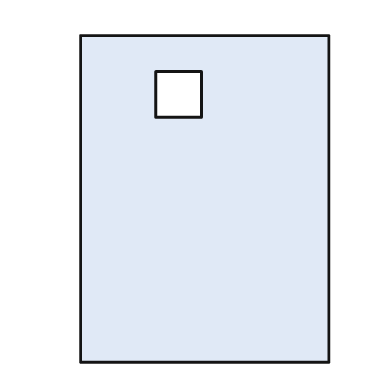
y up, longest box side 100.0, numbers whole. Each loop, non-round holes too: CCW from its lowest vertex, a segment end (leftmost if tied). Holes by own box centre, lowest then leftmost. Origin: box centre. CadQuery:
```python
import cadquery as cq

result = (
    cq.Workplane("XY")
    .moveTo(-38.0, -50.0)
    .lineTo(38.0, -50.0)
    .lineTo(38.0, 50.0)
    .lineTo(-38.0, 50.0)
    .close()
    .moveTo(-15.0, 25.0)
    .lineTo(-1.0, 25.0)
    .lineTo(-1.0, 39.0)
    .lineTo(-15.0, 39.0)
    .close()
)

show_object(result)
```